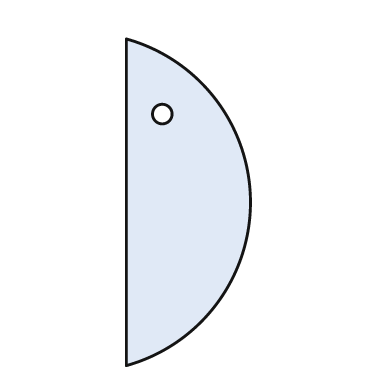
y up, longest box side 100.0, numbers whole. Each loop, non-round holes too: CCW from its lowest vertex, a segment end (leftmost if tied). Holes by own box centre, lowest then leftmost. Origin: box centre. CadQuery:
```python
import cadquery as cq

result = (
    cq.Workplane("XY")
    .moveTo(-19.0, -50.0)
    .threePointArc((19.0, 0.0), (-19.0, 50.0))
    .close()
    .moveTo(-8.0, 27.0)
    .circle(3.0)
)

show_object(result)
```